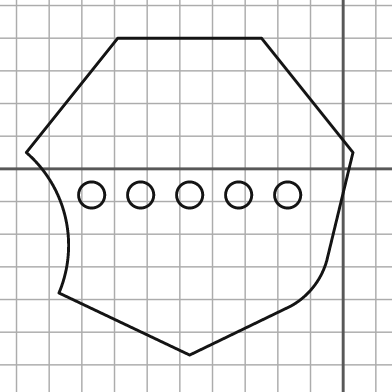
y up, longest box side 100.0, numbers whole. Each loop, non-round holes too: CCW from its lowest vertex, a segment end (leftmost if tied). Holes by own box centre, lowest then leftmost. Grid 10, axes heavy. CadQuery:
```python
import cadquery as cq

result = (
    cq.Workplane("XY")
    .moveTo(-47.0, -57.0)
    .lineTo(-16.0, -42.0)
    .threePointArc((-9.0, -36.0), (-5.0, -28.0))
    .lineTo(3.0, 5.0)
    .lineTo(-25.0, 40.0)
    .lineTo(-69.0, 40.0)
    .lineTo(-97.0, 5.0)
    .threePointArc((-85.0, -15.0), (-87.0, -38.0))
    .close()
    .moveTo(-77.0, -8.0)
    .circle(4.0)
    .moveTo(-62.0, -8.0)
    .circle(4.0)
    .moveTo(-47.0, -8.0)
    .circle(4.0)
    .moveTo(-32.0, -8.0)
    .circle(4.0)
    .moveTo(-17.0, -8.0)
    .circle(4.0)
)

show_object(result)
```